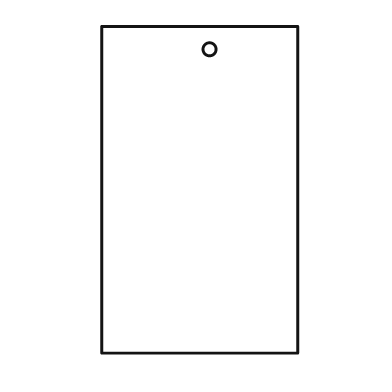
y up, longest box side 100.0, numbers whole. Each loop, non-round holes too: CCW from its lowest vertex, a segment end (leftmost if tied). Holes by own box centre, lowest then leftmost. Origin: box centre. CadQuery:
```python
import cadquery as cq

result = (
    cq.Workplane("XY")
    .moveTo(-30.0, -50.0)
    .lineTo(30.0, -50.0)
    .lineTo(30.0, 50.0)
    .lineTo(-30.0, 50.0)
    .close()
    .moveTo(3.0, 43.0)
    .circle(2.0)
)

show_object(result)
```